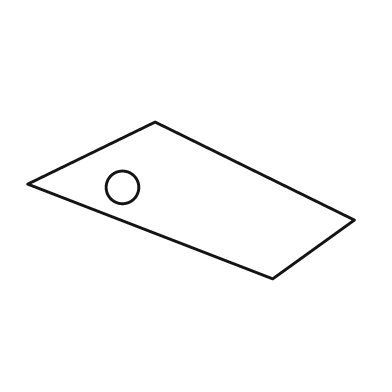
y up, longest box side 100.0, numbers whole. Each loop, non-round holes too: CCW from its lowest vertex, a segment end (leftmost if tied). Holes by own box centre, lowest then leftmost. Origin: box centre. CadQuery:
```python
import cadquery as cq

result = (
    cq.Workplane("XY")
    .moveTo(25.0, -24.0)
    .lineTo(50.0, -6.0)
    .lineTo(-11.0, 24.0)
    .lineTo(-50.0, 5.0)
    .close()
    .moveTo(-21.0, 4.0)
    .circle(5.0)
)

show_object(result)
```